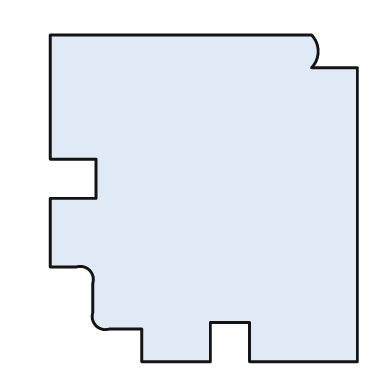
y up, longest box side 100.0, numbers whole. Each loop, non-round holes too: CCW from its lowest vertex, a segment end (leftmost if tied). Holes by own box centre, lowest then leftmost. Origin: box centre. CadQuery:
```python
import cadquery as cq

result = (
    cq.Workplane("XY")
    .moveTo(-19.0, -50.0)
    .lineTo(2.0, -50.0)
    .lineTo(2.0, -38.0)
    .lineTo(14.0, -38.0)
    .lineTo(14.0, -50.0)
    .lineTo(47.0, -50.0)
    .lineTo(47.0, 40.0)
    .lineTo(33.0, 40.0)
    .threePointArc((35.0, 45.0), (33.0, 50.0))
    .lineTo(-47.0, 50.0)
    .lineTo(-47.0, 12.0)
    .lineTo(-33.0, 12.0)
    .lineTo(-33.0, 0.0)
    .lineTo(-47.0, 0.0)
    .lineTo(-47.0, -21.0)
    .lineTo(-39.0, -21.0)
    .threePointArc((-35.0, -22.0), (-34.0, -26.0))
    .lineTo(-34.0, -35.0)
    .threePointArc((-33.0, -39.0), (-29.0, -40.0))
    .lineTo(-19.0, -40.0)
    .close()
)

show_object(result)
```